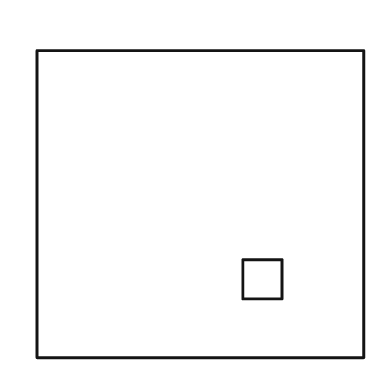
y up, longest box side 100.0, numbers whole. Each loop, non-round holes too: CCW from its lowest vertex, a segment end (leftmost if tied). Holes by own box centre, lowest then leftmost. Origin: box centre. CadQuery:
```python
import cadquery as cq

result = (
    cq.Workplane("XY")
    .moveTo(-50.0, -47.0)
    .lineTo(50.0, -47.0)
    .lineTo(50.0, 47.0)
    .lineTo(-50.0, 47.0)
    .close()
    .moveTo(13.0, -29.0)
    .lineTo(25.0, -29.0)
    .lineTo(25.0, -17.0)
    .lineTo(13.0, -17.0)
    .close()
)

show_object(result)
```